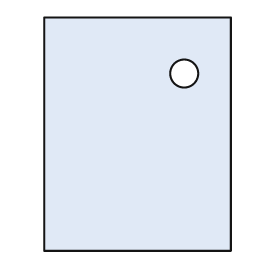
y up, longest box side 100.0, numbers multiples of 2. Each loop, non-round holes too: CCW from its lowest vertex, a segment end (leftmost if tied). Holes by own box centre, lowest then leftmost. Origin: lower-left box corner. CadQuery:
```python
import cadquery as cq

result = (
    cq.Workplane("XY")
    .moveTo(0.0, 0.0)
    .lineTo(80.0, 0.0)
    .lineTo(80.0, 100.0)
    .lineTo(0.0, 100.0)
    .close()
    .moveTo(60.0, 76.0)
    .circle(6.0)
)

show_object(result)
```